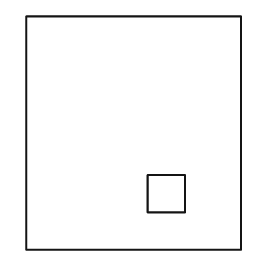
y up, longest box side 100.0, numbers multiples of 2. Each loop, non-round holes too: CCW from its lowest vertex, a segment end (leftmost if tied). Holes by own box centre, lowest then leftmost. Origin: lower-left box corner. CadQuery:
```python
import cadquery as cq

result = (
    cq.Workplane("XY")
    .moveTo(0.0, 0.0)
    .lineTo(92.0, 0.0)
    .lineTo(92.0, 100.0)
    .lineTo(0.0, 100.0)
    .close()
    .moveTo(52.0, 16.0)
    .lineTo(68.0, 16.0)
    .lineTo(68.0, 32.0)
    .lineTo(52.0, 32.0)
    .close()
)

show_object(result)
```